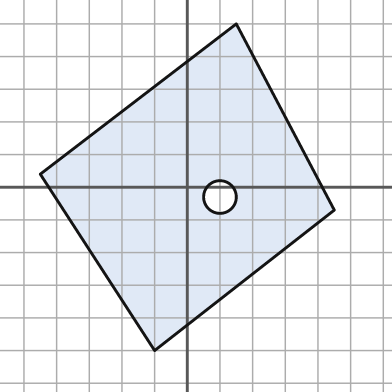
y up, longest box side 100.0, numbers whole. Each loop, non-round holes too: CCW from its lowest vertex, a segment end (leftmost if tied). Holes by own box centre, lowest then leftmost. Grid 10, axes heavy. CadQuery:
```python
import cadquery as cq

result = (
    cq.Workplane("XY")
    .moveTo(-10.0, -50.0)
    .lineTo(45.0, -7.0)
    .lineTo(15.0, 50.0)
    .lineTo(-45.0, 4.0)
    .close()
    .moveTo(10.0, -3.0)
    .circle(5.0)
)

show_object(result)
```